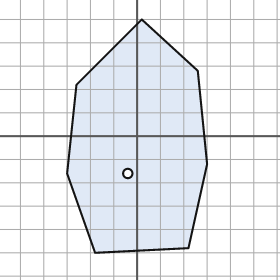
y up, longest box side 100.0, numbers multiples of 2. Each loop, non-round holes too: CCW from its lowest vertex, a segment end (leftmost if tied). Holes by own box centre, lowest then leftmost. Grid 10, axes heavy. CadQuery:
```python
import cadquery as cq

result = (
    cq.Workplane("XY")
    .moveTo(-18.0, -50.0)
    .lineTo(22.0, -48.0)
    .lineTo(30.0, -12.0)
    .lineTo(26.0, 28.0)
    .lineTo(2.0, 50.0)
    .lineTo(-26.0, 22.0)
    .lineTo(-30.0, -16.0)
    .close()
    .moveTo(-4.0, -16.0)
    .circle(2.0)
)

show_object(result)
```